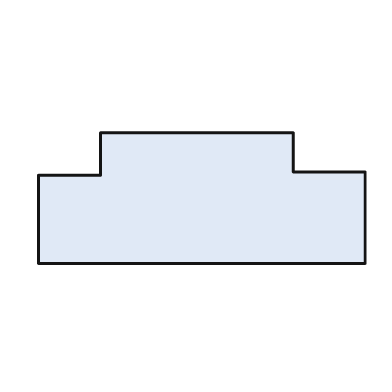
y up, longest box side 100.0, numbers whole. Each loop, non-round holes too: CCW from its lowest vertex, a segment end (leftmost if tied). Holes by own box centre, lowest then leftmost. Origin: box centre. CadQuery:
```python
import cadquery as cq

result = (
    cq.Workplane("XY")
    .moveTo(-50.0, -20.0)
    .lineTo(50.0, -20.0)
    .lineTo(50.0, 8.0)
    .lineTo(28.0, 8.0)
    .lineTo(28.0, 20.0)
    .lineTo(-31.0, 20.0)
    .lineTo(-31.0, 7.0)
    .lineTo(-50.0, 7.0)
    .close()
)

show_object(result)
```